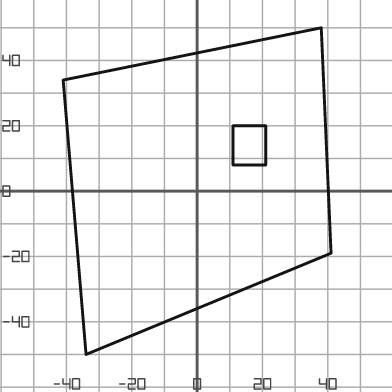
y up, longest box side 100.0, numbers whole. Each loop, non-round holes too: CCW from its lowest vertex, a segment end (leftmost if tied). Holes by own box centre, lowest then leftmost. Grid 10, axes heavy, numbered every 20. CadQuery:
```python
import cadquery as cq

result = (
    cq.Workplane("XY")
    .moveTo(-34.0, -50.0)
    .lineTo(41.0, -19.0)
    .lineTo(38.0, 50.0)
    .lineTo(-41.0, 34.0)
    .close()
    .moveTo(11.0, 8.0)
    .lineTo(21.0, 8.0)
    .lineTo(21.0, 20.0)
    .lineTo(11.0, 20.0)
    .close()
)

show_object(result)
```